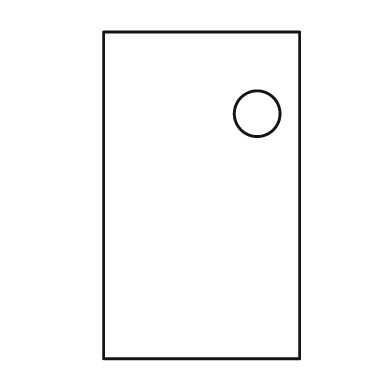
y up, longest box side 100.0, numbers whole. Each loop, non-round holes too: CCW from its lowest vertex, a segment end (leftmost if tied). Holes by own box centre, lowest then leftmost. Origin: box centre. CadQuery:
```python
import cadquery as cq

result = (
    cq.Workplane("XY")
    .moveTo(-30.0, -50.0)
    .lineTo(30.0, -50.0)
    .lineTo(30.0, 50.0)
    .lineTo(-30.0, 50.0)
    .close()
    .moveTo(17.0, 25.0)
    .circle(7.0)
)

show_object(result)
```